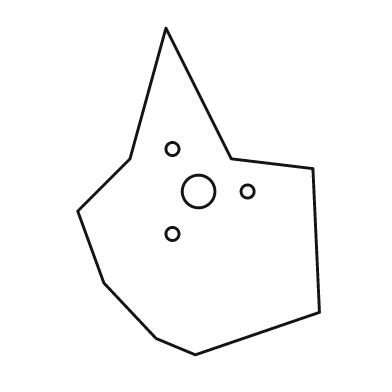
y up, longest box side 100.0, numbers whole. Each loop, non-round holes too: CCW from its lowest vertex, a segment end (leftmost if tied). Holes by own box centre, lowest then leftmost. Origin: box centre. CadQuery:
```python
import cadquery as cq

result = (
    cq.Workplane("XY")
    .moveTo(-1.0, -50.0)
    .lineTo(37.0, -37.0)
    .lineTo(35.0, 7.0)
    .lineTo(10.0, 10.0)
    .lineTo(-10.0, 50.0)
    .lineTo(-21.0, 10.0)
    .lineTo(-37.0, -6.0)
    .lineTo(-29.0, -28.0)
    .lineTo(-13.0, -45.0)
    .close()
    .moveTo(-8.0, -13.0)
    .circle(2.0)
    .moveTo(0.0, 0.0)
    .circle(5.0)
    .moveTo(15.0, 0.0)
    .circle(2.0)
    .moveTo(-8.0, 13.0)
    .circle(2.0)
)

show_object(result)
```